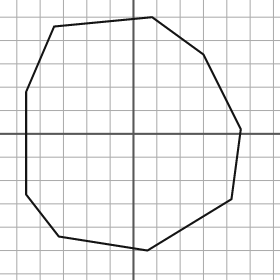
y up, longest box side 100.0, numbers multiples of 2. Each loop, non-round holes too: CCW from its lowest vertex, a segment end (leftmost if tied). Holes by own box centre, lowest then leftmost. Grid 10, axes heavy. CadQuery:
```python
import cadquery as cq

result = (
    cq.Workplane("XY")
    .moveTo(6.0, -50.0)
    .lineTo(42.0, -28.0)
    .lineTo(46.0, 2.0)
    .lineTo(30.0, 34.0)
    .lineTo(8.0, 50.0)
    .lineTo(-34.0, 46.0)
    .lineTo(-46.0, 18.0)
    .lineTo(-46.0, -26.0)
    .lineTo(-32.0, -44.0)
    .close()
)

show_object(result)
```